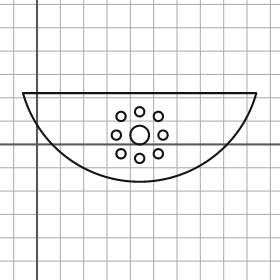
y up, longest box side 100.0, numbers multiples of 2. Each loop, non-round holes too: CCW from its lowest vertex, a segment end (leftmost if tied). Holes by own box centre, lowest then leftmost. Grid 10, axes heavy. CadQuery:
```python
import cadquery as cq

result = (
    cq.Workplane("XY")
    .moveTo(-6.0, 22.0)
    .threePointArc((44.0, -16.0), (94.0, 22.0))
    .close()
    .moveTo(44.0, -6.0)
    .circle(2.0)
    .moveTo(36.0, -4.0)
    .circle(2.0)
    .moveTo(52.0, -4.0)
    .circle(2.0)
    .moveTo(34.0, 4.0)
    .circle(2.0)
    .moveTo(44.0, 4.0)
    .circle(4.0)
    .moveTo(54.0, 4.0)
    .circle(2.0)
    .moveTo(36.0, 12.0)
    .circle(2.0)
    .moveTo(52.0, 12.0)
    .circle(2.0)
    .moveTo(44.0, 14.0)
    .circle(2.0)
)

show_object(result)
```